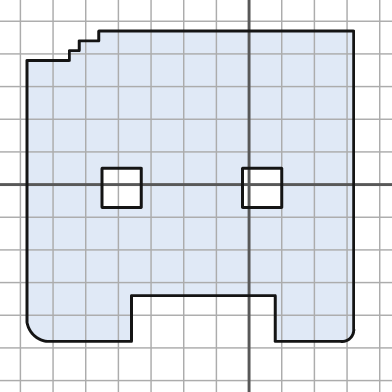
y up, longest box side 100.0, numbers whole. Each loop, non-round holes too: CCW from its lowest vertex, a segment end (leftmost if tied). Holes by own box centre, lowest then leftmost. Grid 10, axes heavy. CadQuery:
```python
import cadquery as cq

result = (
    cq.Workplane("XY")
    .moveTo(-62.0, -48.0)
    .lineTo(-36.0, -48.0)
    .lineTo(-36.0, -34.0)
    .lineTo(8.0, -34.0)
    .lineTo(8.0, -48.0)
    .lineTo(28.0, -48.0)
    .threePointArc((31.0, -47.0), (32.0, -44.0))
    .lineTo(32.0, 47.0)
    .lineTo(-46.0, 47.0)
    .lineTo(-46.0, 44.0)
    .lineTo(-52.0, 44.0)
    .lineTo(-52.0, 41.0)
    .lineTo(-55.0, 41.0)
    .lineTo(-55.0, 38.0)
    .lineTo(-68.0, 38.0)
    .lineTo(-68.0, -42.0)
    .threePointArc((-66.0, -46.0), (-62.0, -48.0))
    .close()
    .moveTo(-45.0, -7.0)
    .lineTo(-33.0, -7.0)
    .lineTo(-33.0, 5.0)
    .lineTo(-45.0, 5.0)
    .close()
    .moveTo(-2.0, -7.0)
    .lineTo(10.0, -7.0)
    .lineTo(10.0, 5.0)
    .lineTo(-2.0, 5.0)
    .close()
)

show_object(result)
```